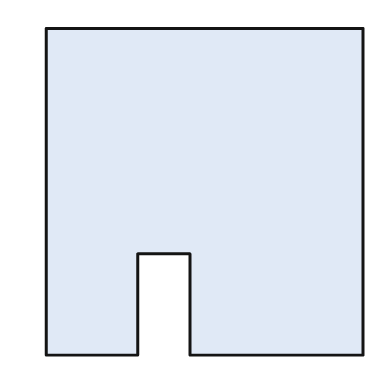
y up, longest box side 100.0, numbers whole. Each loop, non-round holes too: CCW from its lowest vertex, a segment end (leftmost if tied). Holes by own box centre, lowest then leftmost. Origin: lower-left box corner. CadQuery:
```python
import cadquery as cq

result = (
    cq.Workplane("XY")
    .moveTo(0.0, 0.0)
    .lineTo(28.0, 0.0)
    .lineTo(28.0, 31.0)
    .lineTo(44.0, 31.0)
    .lineTo(44.0, 0.0)
    .lineTo(97.0, 0.0)
    .lineTo(97.0, 100.0)
    .lineTo(0.0, 100.0)
    .close()
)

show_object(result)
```